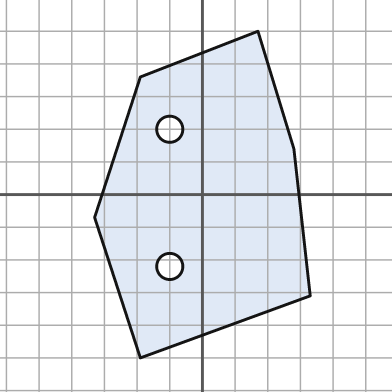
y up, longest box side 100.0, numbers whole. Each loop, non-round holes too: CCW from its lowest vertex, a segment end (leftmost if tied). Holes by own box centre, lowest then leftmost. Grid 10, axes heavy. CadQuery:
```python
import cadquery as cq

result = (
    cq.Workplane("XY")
    .moveTo(-19.0, -50.0)
    .lineTo(33.0, -31.0)
    .lineTo(28.0, 14.0)
    .lineTo(17.0, 50.0)
    .lineTo(-19.0, 36.0)
    .lineTo(-33.0, -7.0)
    .close()
    .moveTo(-10.0, -22.0)
    .circle(4.0)
    .moveTo(-10.0, 20.0)
    .circle(4.0)
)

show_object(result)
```